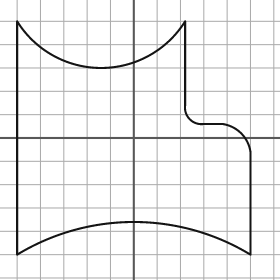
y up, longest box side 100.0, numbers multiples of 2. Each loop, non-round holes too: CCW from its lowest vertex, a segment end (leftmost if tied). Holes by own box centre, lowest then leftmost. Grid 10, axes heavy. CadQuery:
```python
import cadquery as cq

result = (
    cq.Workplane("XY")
    .moveTo(-50.0, -50.0)
    .threePointArc((0.0, -36.0), (50.0, -50.0))
    .lineTo(50.0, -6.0)
    .threePointArc((46.0, 2.0), (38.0, 6.0))
    .lineTo(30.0, 6.0)
    .threePointArc((24.0, 8.0), (22.0, 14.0))
    .lineTo(22.0, 50.0)
    .threePointArc((-14.0, 30.0), (-50.0, 50.0))
    .close()
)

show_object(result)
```